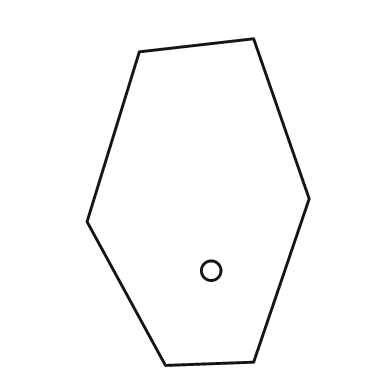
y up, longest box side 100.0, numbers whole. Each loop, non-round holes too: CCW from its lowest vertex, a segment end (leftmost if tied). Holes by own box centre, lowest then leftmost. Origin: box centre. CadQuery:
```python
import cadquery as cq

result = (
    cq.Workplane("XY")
    .moveTo(-10.0, -50.0)
    .lineTo(17.0, -49.0)
    .lineTo(34.0, 1.0)
    .lineTo(17.0, 50.0)
    .lineTo(-18.0, 46.0)
    .lineTo(-34.0, -6.0)
    .close()
    .moveTo(4.0, -21.0)
    .circle(3.0)
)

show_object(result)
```